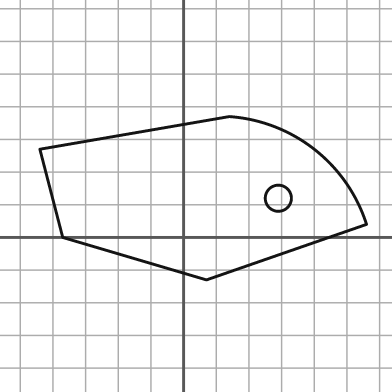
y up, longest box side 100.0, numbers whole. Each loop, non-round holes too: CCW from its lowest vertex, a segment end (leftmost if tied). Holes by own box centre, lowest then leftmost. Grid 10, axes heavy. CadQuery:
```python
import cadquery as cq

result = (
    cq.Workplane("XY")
    .moveTo(7.0, -13.0)
    .lineTo(56.0, 4.0)
    .threePointArc((40.0, 27.0), (14.0, 37.0))
    .lineTo(-44.0, 27.0)
    .lineTo(-37.0, 0.0)
    .close()
    .moveTo(29.0, 12.0)
    .circle(4.0)
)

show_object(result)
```